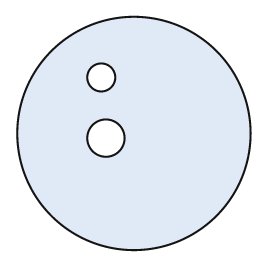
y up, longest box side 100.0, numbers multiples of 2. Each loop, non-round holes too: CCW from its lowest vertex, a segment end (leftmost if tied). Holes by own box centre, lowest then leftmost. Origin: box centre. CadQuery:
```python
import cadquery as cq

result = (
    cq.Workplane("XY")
    .moveTo(0.0, 0.0)
    .circle(50.0)
    .moveTo(-12.0, -2.0)
    .circle(8.0)
    .moveTo(-14.0, 24.0)
    .circle(6.0)
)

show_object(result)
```